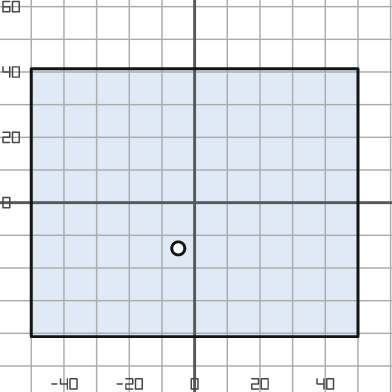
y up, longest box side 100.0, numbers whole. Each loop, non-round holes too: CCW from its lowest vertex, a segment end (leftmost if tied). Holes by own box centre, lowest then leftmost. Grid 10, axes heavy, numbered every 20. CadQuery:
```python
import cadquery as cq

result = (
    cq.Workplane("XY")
    .moveTo(-50.0, -41.0)
    .lineTo(50.0, -41.0)
    .lineTo(50.0, 41.0)
    .lineTo(-50.0, 41.0)
    .close()
    .moveTo(-5.0, -14.0)
    .circle(2.0)
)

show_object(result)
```